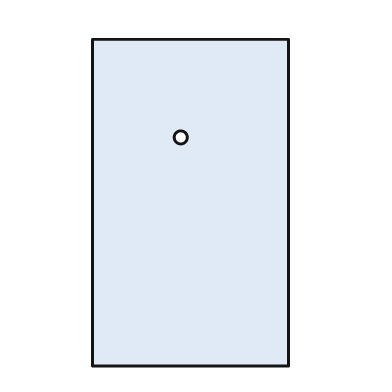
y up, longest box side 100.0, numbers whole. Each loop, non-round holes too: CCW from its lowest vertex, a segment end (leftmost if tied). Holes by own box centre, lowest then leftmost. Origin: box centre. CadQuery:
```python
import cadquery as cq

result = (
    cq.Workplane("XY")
    .moveTo(-30.0, -50.0)
    .lineTo(30.0, -50.0)
    .lineTo(30.0, 50.0)
    .lineTo(-30.0, 50.0)
    .close()
    .moveTo(-3.0, 20.0)
    .circle(2.0)
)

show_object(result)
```